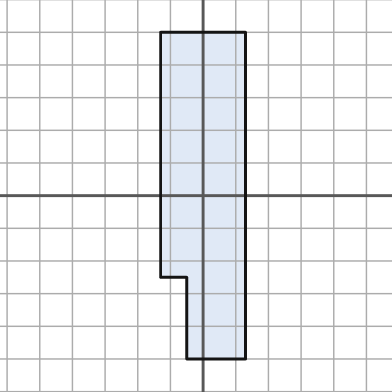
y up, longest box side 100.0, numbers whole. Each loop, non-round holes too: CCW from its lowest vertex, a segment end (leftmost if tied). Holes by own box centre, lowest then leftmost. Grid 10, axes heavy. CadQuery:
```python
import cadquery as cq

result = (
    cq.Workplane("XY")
    .moveTo(-5.0, -50.0)
    .lineTo(13.0, -50.0)
    .lineTo(13.0, 50.0)
    .lineTo(-13.0, 50.0)
    .lineTo(-13.0, -25.0)
    .lineTo(-5.0, -25.0)
    .close()
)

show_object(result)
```